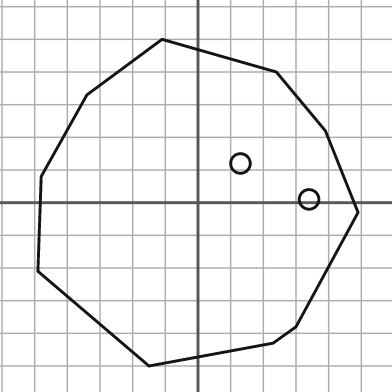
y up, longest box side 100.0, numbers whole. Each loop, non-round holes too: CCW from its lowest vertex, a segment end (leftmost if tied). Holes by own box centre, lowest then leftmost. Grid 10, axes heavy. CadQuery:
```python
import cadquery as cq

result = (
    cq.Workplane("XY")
    .moveTo(-15.0, -50.0)
    .lineTo(23.0, -43.0)
    .lineTo(30.0, -38.0)
    .lineTo(49.0, -3.0)
    .lineTo(39.0, 22.0)
    .lineTo(24.0, 40.0)
    .lineTo(-11.0, 50.0)
    .lineTo(-34.0, 33.0)
    .lineTo(-48.0, 8.0)
    .lineTo(-49.0, -21.0)
    .close()
    .moveTo(34.0, 1.0)
    .circle(3.0)
    .moveTo(13.0, 12.0)
    .circle(3.0)
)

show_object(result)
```